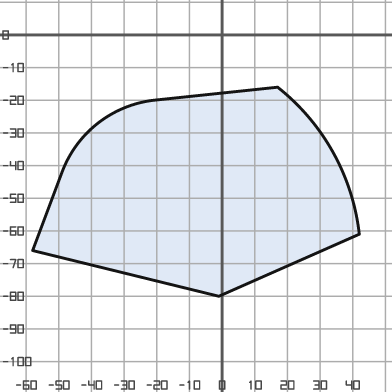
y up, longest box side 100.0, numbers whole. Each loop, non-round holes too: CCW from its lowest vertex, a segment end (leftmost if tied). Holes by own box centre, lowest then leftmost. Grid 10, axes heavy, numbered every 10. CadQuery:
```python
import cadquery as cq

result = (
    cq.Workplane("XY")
    .moveTo(-1.0, -80.0)
    .lineTo(42.0, -61.0)
    .threePointArc((34.0, -36.0), (17.0, -16.0))
    .lineTo(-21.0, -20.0)
    .threePointArc((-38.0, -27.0), (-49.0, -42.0))
    .lineTo(-58.0, -66.0)
    .close()
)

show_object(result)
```